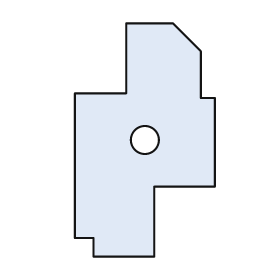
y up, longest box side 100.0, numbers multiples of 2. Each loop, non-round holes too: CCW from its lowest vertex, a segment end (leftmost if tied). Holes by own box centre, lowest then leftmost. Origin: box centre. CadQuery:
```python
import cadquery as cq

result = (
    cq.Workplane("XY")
    .moveTo(-22.0, -50.0)
    .lineTo(4.0, -50.0)
    .lineTo(4.0, -20.0)
    .lineTo(30.0, -20.0)
    .lineTo(30.0, 18.0)
    .lineTo(24.0, 18.0)
    .lineTo(24.0, 38.0)
    .lineTo(12.0, 50.0)
    .lineTo(-8.0, 50.0)
    .lineTo(-8.0, 20.0)
    .lineTo(-30.0, 20.0)
    .lineTo(-30.0, -42.0)
    .lineTo(-22.0, -42.0)
    .close()
    .moveTo(0.0, 0.0)
    .circle(6.0)
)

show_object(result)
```